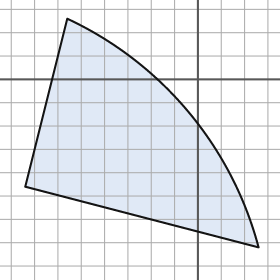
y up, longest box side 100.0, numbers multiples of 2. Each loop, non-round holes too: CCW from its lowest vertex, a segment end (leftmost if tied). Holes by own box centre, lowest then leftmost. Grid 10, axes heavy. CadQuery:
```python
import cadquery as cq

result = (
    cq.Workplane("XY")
    .moveTo(26.0, -72.0)
    .threePointArc((-4.0, -14.0), (-56.0, 26.0))
    .lineTo(-74.0, -46.0)
    .close()
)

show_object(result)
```